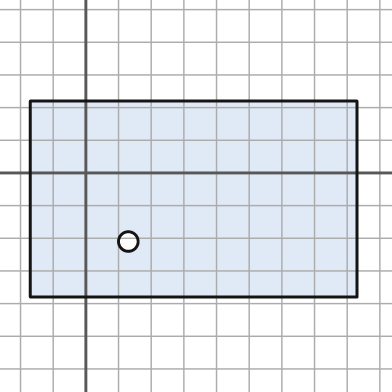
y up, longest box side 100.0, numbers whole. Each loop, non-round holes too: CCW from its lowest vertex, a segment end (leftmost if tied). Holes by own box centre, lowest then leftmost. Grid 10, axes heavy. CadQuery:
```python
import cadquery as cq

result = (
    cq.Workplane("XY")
    .moveTo(-17.0, -38.0)
    .lineTo(83.0, -38.0)
    .lineTo(83.0, 22.0)
    .lineTo(-17.0, 22.0)
    .close()
    .moveTo(13.0, -21.0)
    .circle(3.0)
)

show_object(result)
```